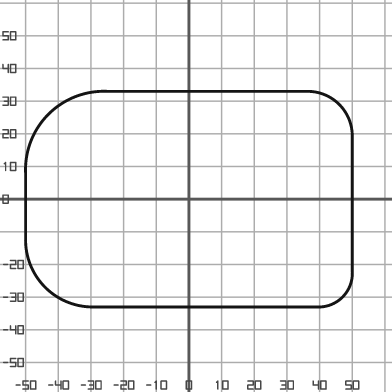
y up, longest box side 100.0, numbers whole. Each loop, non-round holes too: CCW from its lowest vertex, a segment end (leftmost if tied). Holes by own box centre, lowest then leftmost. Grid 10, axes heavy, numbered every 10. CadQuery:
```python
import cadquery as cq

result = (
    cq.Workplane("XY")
    .moveTo(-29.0, -33.0)
    .lineTo(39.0, -33.0)
    .threePointArc((47.0, -30.0), (50.0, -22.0))
    .lineTo(50.0, 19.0)
    .threePointArc((46.0, 29.0), (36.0, 33.0))
    .lineTo(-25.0, 33.0)
    .threePointArc((-43.0, 26.0), (-50.0, 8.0))
    .lineTo(-50.0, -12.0)
    .threePointArc((-44.0, -27.0), (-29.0, -33.0))
    .close()
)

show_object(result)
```